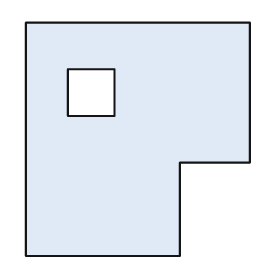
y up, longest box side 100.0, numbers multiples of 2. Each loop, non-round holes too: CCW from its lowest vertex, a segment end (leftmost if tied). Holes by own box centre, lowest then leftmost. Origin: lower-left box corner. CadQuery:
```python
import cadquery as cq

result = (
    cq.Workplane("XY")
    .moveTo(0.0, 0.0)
    .lineTo(66.0, 0.0)
    .lineTo(66.0, 40.0)
    .lineTo(96.0, 40.0)
    .lineTo(96.0, 100.0)
    .lineTo(0.0, 100.0)
    .close()
    .moveTo(18.0, 60.0)
    .lineTo(38.0, 60.0)
    .lineTo(38.0, 80.0)
    .lineTo(18.0, 80.0)
    .close()
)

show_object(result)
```